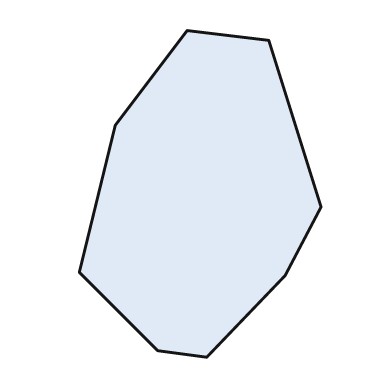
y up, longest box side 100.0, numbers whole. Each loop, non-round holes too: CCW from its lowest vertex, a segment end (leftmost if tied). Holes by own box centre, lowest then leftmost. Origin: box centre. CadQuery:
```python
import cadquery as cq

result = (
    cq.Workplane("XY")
    .moveTo(2.0, -50.0)
    .lineTo(26.0, -25.0)
    .lineTo(37.0, -4.0)
    .lineTo(21.0, 47.0)
    .lineTo(-4.0, 50.0)
    .lineTo(-26.0, 21.0)
    .lineTo(-37.0, -24.0)
    .lineTo(-13.0, -48.0)
    .close()
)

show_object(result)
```